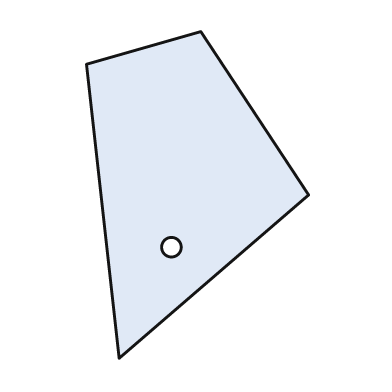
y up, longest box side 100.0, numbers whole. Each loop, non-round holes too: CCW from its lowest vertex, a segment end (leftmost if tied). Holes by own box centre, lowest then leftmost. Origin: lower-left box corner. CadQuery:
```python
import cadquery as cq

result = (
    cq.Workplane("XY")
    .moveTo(10.0, 0.0)
    .lineTo(68.0, 50.0)
    .lineTo(35.0, 100.0)
    .lineTo(0.0, 90.0)
    .close()
    .moveTo(26.0, 34.0)
    .circle(3.0)
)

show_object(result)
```